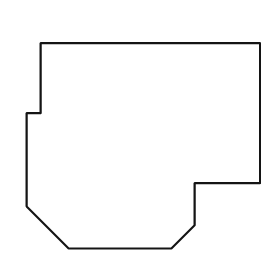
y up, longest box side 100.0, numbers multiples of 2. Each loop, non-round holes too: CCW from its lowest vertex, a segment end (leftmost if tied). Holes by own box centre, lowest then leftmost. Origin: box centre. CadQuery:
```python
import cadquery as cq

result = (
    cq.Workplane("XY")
    .moveTo(-32.0, -44.0)
    .lineTo(12.0, -44.0)
    .lineTo(22.0, -34.0)
    .lineTo(22.0, -16.0)
    .lineTo(50.0, -16.0)
    .lineTo(50.0, 44.0)
    .lineTo(-44.0, 44.0)
    .lineTo(-44.0, 14.0)
    .lineTo(-50.0, 14.0)
    .lineTo(-50.0, -26.0)
    .close()
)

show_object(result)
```